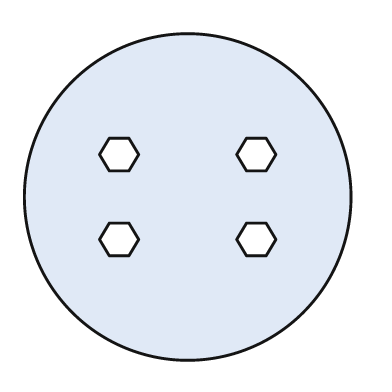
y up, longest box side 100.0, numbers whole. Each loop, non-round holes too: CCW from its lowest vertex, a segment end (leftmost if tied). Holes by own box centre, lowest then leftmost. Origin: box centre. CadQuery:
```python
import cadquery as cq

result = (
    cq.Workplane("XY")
    .moveTo(0.0, 0.0)
    .circle(50.0)
    .moveTo(-24.0, -18.0)
    .lineTo(-18.0, -18.0)
    .lineTo(-15.0, -13.0)
    .lineTo(-18.0, -8.0)
    .lineTo(-24.0, -8.0)
    .lineTo(-27.0, -13.0)
    .close()
    .moveTo(18.0, -18.0)
    .lineTo(24.0, -18.0)
    .lineTo(27.0, -13.0)
    .lineTo(24.0, -8.0)
    .lineTo(18.0, -8.0)
    .lineTo(15.0, -13.0)
    .close()
    .moveTo(-24.0, 8.0)
    .lineTo(-18.0, 8.0)
    .lineTo(-15.0, 13.0)
    .lineTo(-18.0, 18.0)
    .lineTo(-24.0, 18.0)
    .lineTo(-27.0, 13.0)
    .close()
    .moveTo(18.0, 8.0)
    .lineTo(24.0, 8.0)
    .lineTo(27.0, 13.0)
    .lineTo(24.0, 18.0)
    .lineTo(18.0, 18.0)
    .lineTo(15.0, 13.0)
    .close()
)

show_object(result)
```